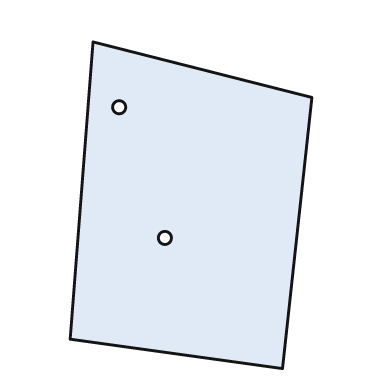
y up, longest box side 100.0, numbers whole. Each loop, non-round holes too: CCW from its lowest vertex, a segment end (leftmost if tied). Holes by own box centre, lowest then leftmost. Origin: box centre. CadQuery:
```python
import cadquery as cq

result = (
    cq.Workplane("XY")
    .moveTo(28.0, -50.0)
    .lineTo(37.0, 33.0)
    .lineTo(-30.0, 50.0)
    .lineTo(-37.0, -41.0)
    .close()
    .moveTo(-8.0, -10.0)
    .circle(2.0)
    .moveTo(-22.0, 30.0)
    .circle(2.0)
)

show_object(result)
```